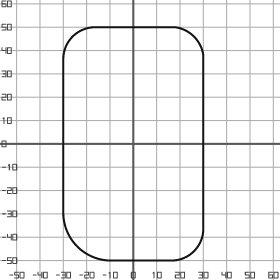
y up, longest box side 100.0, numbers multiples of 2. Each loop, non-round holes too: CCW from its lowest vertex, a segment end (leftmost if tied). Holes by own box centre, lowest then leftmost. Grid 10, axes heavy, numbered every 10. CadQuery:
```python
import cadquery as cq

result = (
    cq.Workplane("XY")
    .moveTo(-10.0, -50.0)
    .lineTo(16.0, -50.0)
    .threePointArc((26.0, -46.0), (30.0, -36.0))
    .lineTo(30.0, 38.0)
    .threePointArc((26.0, 46.0), (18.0, 50.0))
    .lineTo(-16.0, 50.0)
    .threePointArc((-26.0, 46.0), (-30.0, 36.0))
    .lineTo(-30.0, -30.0)
    .threePointArc((-24.0, -44.0), (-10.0, -50.0))
    .close()
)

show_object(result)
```